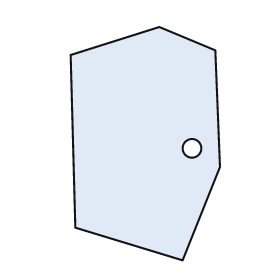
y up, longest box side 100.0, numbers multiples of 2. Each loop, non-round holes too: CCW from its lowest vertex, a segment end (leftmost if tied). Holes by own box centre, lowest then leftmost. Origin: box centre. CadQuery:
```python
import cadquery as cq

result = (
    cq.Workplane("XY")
    .moveTo(16.0, -50.0)
    .lineTo(32.0, -10.0)
    .lineTo(30.0, 40.0)
    .lineTo(6.0, 50.0)
    .lineTo(-32.0, 38.0)
    .lineTo(-30.0, -36.0)
    .close()
    .moveTo(20.0, -2.0)
    .circle(4.0)
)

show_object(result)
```